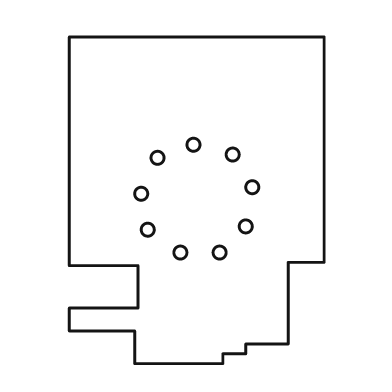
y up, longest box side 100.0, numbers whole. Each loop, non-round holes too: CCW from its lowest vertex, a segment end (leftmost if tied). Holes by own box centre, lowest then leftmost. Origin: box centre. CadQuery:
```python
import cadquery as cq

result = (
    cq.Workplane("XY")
    .moveTo(-19.0, -50.0)
    .lineTo(8.0, -50.0)
    .lineTo(8.0, -47.0)
    .lineTo(15.0, -47.0)
    .lineTo(15.0, -44.0)
    .lineTo(28.0, -44.0)
    .lineTo(28.0, -19.0)
    .lineTo(39.0, -19.0)
    .lineTo(39.0, 50.0)
    .lineTo(-39.0, 50.0)
    .lineTo(-39.0, -20.0)
    .lineTo(-18.0, -20.0)
    .lineTo(-18.0, -33.0)
    .lineTo(-39.0, -33.0)
    .lineTo(-39.0, -40.0)
    .lineTo(-19.0, -40.0)
    .close()
    .moveTo(-5.0, -16.0)
    .circle(2.0)
    .moveTo(7.0, -16.0)
    .circle(2.0)
    .moveTo(-15.0, -9.0)
    .circle(2.0)
    .moveTo(15.0, -8.0)
    .circle(2.0)
    .moveTo(-17.0, 2.0)
    .circle(2.0)
    .moveTo(17.0, 4.0)
    .circle(2.0)
    .moveTo(-12.0, 13.0)
    .circle(2.0)
    .moveTo(11.0, 14.0)
    .circle(2.0)
    .moveTo(-1.0, 17.0)
    .circle(2.0)
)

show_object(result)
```